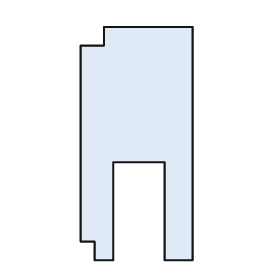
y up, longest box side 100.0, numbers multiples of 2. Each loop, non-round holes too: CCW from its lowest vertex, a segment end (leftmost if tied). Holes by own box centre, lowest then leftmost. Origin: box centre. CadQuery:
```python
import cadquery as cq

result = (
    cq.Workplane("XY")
    .moveTo(-18.0, -50.0)
    .lineTo(-10.0, -50.0)
    .lineTo(-10.0, -8.0)
    .lineTo(12.0, -8.0)
    .lineTo(12.0, -50.0)
    .lineTo(24.0, -50.0)
    .lineTo(24.0, 50.0)
    .lineTo(-14.0, 50.0)
    .lineTo(-14.0, 42.0)
    .lineTo(-24.0, 42.0)
    .lineTo(-24.0, -42.0)
    .lineTo(-18.0, -42.0)
    .close()
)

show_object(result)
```